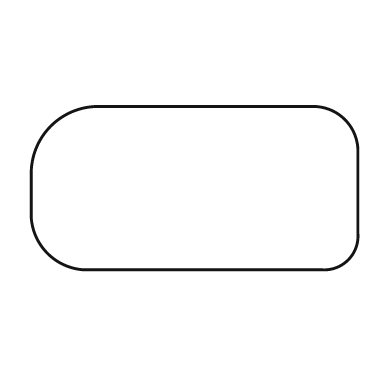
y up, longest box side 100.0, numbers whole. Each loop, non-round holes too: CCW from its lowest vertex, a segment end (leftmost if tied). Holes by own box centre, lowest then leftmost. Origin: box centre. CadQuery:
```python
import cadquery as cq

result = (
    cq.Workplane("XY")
    .moveTo(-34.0, -25.0)
    .lineTo(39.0, -25.0)
    .threePointArc((47.0, -22.0), (50.0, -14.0))
    .lineTo(50.0, 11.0)
    .threePointArc((46.0, 21.0), (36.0, 25.0))
    .lineTo(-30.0, 25.0)
    .threePointArc((-44.0, 19.0), (-50.0, 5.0))
    .lineTo(-50.0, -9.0)
    .threePointArc((-45.0, -20.0), (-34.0, -25.0))
    .close()
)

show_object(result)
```